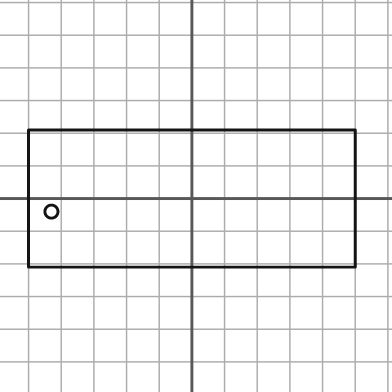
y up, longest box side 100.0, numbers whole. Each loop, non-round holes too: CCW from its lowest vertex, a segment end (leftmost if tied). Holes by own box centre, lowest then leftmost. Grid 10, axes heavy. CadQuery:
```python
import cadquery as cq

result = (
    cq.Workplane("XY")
    .moveTo(-50.0, -21.0)
    .lineTo(50.0, -21.0)
    .lineTo(50.0, 21.0)
    .lineTo(-50.0, 21.0)
    .close()
    .moveTo(-43.0, -4.0)
    .circle(2.0)
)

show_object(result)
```